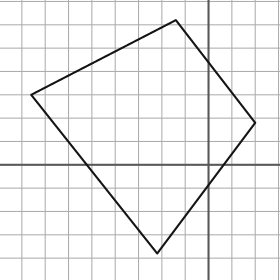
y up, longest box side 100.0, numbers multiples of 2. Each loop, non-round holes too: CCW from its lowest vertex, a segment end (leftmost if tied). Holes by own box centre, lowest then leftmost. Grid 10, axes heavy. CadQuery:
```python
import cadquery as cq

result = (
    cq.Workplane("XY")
    .moveTo(-22.0, -38.0)
    .lineTo(20.0, 18.0)
    .lineTo(-14.0, 62.0)
    .lineTo(-76.0, 30.0)
    .close()
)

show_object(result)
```